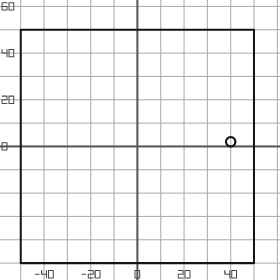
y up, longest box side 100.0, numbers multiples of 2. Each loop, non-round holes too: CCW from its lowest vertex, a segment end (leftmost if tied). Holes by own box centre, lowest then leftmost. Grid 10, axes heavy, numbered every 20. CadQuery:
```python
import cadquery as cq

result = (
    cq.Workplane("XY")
    .moveTo(-50.0, -50.0)
    .lineTo(50.0, -50.0)
    .lineTo(50.0, 50.0)
    .lineTo(-50.0, 50.0)
    .close()
    .moveTo(40.0, 2.0)
    .circle(2.0)
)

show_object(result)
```